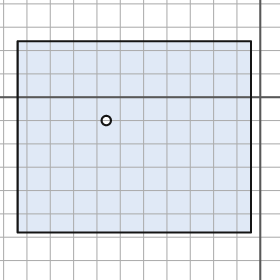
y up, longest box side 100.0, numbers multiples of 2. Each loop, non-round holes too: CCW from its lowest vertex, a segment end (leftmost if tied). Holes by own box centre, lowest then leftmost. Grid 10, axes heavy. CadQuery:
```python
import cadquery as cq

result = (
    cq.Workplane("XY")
    .moveTo(-104.0, -58.0)
    .lineTo(-4.0, -58.0)
    .lineTo(-4.0, 24.0)
    .lineTo(-104.0, 24.0)
    .close()
    .moveTo(-66.0, -10.0)
    .circle(2.0)
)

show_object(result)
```